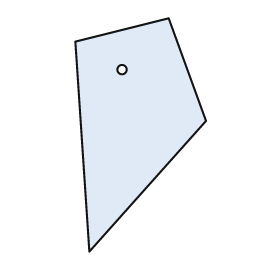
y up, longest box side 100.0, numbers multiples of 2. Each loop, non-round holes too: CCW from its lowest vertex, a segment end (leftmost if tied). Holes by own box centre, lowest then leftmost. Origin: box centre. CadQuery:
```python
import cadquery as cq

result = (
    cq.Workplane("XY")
    .moveTo(-22.0, -50.0)
    .lineTo(28.0, 6.0)
    .lineTo(12.0, 50.0)
    .lineTo(-28.0, 40.0)
    .close()
    .moveTo(-8.0, 28.0)
    .circle(2.0)
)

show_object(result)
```